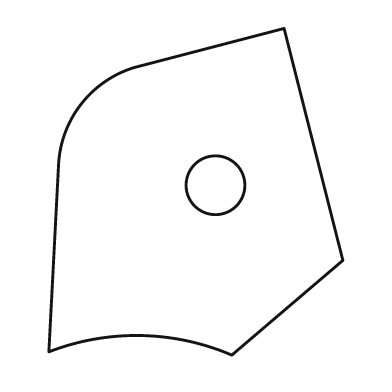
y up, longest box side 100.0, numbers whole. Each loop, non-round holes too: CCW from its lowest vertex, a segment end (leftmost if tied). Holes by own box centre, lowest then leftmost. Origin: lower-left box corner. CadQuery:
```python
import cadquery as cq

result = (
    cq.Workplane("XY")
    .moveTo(56.0, 0.0)
    .lineTo(90.0, 29.0)
    .lineTo(72.0, 100.0)
    .lineTo(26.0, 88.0)
    .threePointArc((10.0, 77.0), (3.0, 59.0))
    .lineTo(0.0, 1.0)
    .threePointArc((28.0, 6.0), (56.0, 0.0))
    .close()
    .moveTo(51.0, 52.0)
    .circle(9.0)
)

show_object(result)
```